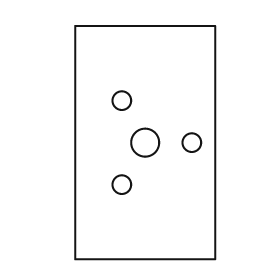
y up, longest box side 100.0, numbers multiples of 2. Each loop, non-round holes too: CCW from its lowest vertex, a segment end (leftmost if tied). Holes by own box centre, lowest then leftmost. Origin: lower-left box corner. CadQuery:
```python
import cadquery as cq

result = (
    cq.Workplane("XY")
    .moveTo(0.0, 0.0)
    .lineTo(60.0, 0.0)
    .lineTo(60.0, 100.0)
    .lineTo(0.0, 100.0)
    .close()
    .moveTo(20.0, 32.0)
    .circle(4.0)
    .moveTo(30.0, 50.0)
    .circle(6.0)
    .moveTo(50.0, 50.0)
    .circle(4.0)
    .moveTo(20.0, 68.0)
    .circle(4.0)
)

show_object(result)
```